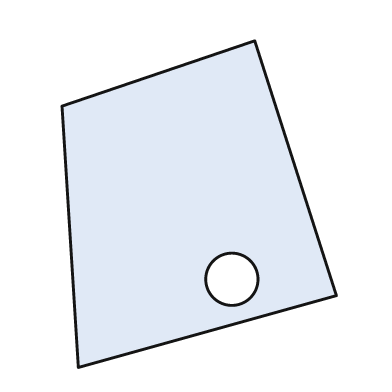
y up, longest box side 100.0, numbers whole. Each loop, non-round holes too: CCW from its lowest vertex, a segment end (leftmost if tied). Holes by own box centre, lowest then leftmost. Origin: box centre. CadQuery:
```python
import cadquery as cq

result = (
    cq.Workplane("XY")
    .moveTo(-37.0, -50.0)
    .lineTo(42.0, -28.0)
    .lineTo(17.0, 50.0)
    .lineTo(-42.0, 30.0)
    .close()
    .moveTo(10.0, -23.0)
    .circle(8.0)
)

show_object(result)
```